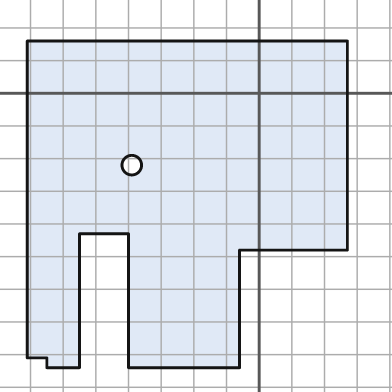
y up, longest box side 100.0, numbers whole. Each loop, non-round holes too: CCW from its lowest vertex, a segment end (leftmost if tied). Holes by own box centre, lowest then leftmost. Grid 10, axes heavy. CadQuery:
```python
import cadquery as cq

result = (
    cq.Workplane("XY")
    .moveTo(-65.0, -84.0)
    .lineTo(-55.0, -84.0)
    .lineTo(-55.0, -43.0)
    .lineTo(-40.0, -43.0)
    .lineTo(-40.0, -84.0)
    .lineTo(-6.0, -84.0)
    .lineTo(-6.0, -48.0)
    .lineTo(27.0, -48.0)
    .lineTo(27.0, 16.0)
    .lineTo(-71.0, 16.0)
    .lineTo(-71.0, -81.0)
    .lineTo(-65.0, -81.0)
    .close()
    .moveTo(-39.0, -22.0)
    .circle(3.0)
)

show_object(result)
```